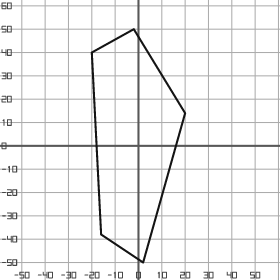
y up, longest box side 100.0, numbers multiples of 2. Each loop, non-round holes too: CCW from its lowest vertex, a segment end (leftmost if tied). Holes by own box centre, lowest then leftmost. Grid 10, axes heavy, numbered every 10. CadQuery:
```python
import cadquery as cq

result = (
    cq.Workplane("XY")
    .moveTo(2.0, -50.0)
    .lineTo(20.0, 14.0)
    .lineTo(-2.0, 50.0)
    .lineTo(-20.0, 40.0)
    .lineTo(-16.0, -38.0)
    .close()
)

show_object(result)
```